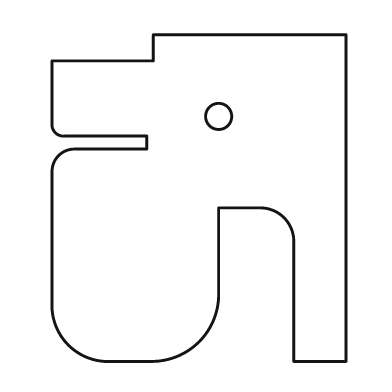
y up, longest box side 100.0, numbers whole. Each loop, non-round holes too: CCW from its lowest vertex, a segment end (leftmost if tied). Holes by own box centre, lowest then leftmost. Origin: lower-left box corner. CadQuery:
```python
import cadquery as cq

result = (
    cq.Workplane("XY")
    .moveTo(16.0, 0.0)
    .lineTo(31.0, 0.0)
    .threePointArc((45.0, 6.0), (51.0, 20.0))
    .lineTo(51.0, 47.0)
    .lineTo(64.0, 47.0)
    .threePointArc((71.0, 44.0), (74.0, 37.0))
    .lineTo(74.0, 0.0)
    .lineTo(90.0, 0.0)
    .lineTo(90.0, 100.0)
    .lineTo(31.0, 100.0)
    .lineTo(31.0, 92.0)
    .lineTo(0.0, 92.0)
    .lineTo(0.0, 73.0)
    .threePointArc((1.0, 70.0), (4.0, 69.0))
    .lineTo(29.0, 69.0)
    .lineTo(29.0, 65.0)
    .lineTo(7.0, 65.0)
    .threePointArc((2.0, 63.0), (0.0, 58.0))
    .lineTo(0.0, 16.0)
    .threePointArc((5.0, 5.0), (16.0, 0.0))
    .close()
    .moveTo(51.0, 75.0)
    .circle(4.0)
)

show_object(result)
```